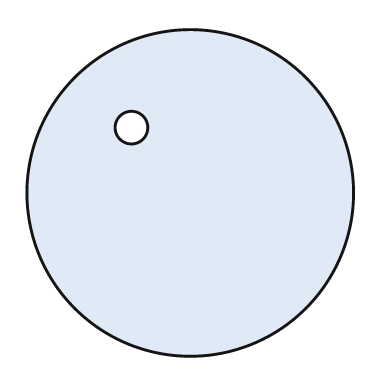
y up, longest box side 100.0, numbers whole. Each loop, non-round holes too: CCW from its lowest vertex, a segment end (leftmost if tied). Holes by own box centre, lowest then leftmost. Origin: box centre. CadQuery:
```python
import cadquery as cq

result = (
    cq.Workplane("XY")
    .moveTo(0.0, 0.0)
    .circle(50.0)
    .moveTo(-18.0, 20.0)
    .circle(5.0)
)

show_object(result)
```